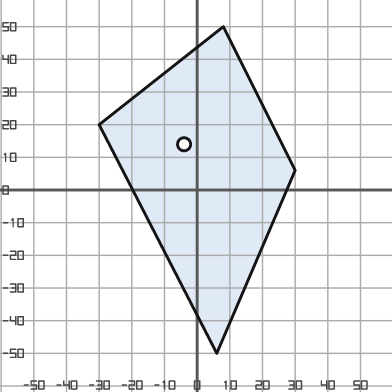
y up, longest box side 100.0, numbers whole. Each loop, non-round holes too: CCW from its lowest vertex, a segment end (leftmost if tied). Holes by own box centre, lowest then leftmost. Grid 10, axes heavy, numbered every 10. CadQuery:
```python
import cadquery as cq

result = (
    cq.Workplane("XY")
    .moveTo(6.0, -50.0)
    .lineTo(30.0, 6.0)
    .lineTo(8.0, 50.0)
    .lineTo(-30.0, 20.0)
    .close()
    .moveTo(-4.0, 14.0)
    .circle(2.0)
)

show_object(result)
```